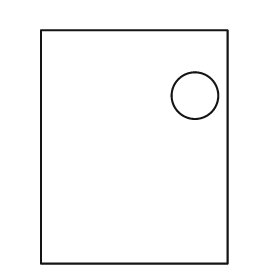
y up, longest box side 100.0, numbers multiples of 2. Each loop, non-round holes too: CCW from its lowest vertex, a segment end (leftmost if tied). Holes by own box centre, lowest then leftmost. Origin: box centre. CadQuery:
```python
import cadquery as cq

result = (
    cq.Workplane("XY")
    .moveTo(-40.0, -50.0)
    .lineTo(40.0, -50.0)
    .lineTo(40.0, 50.0)
    .lineTo(-40.0, 50.0)
    .close()
    .moveTo(26.0, 22.0)
    .circle(10.0)
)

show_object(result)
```